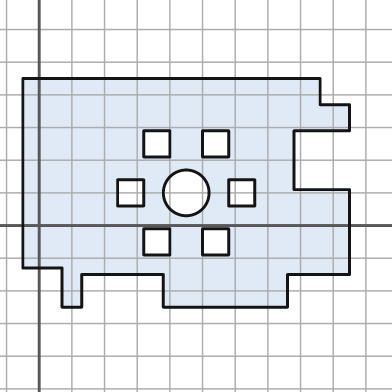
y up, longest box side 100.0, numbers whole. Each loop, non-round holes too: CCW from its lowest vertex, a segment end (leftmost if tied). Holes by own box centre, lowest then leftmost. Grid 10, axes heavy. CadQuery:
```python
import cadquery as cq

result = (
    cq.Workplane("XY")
    .moveTo(7.0, -25.0)
    .lineTo(13.0, -25.0)
    .lineTo(13.0, -15.0)
    .lineTo(38.0, -15.0)
    .lineTo(38.0, -25.0)
    .lineTo(76.0, -25.0)
    .lineTo(76.0, -15.0)
    .lineTo(95.0, -15.0)
    .lineTo(95.0, 11.0)
    .lineTo(78.0, 11.0)
    .lineTo(78.0, 29.0)
    .lineTo(95.0, 29.0)
    .lineTo(95.0, 37.0)
    .lineTo(86.0, 37.0)
    .lineTo(86.0, 45.0)
    .lineTo(-5.0, 45.0)
    .lineTo(-5.0, -13.0)
    .lineTo(7.0, -13.0)
    .close()
    .moveTo(32.0, -9.0)
    .lineTo(40.0, -9.0)
    .lineTo(40.0, -1.0)
    .lineTo(32.0, -1.0)
    .close()
    .moveTo(50.0, -9.0)
    .lineTo(58.0, -9.0)
    .lineTo(58.0, -1.0)
    .lineTo(50.0, -1.0)
    .close()
    .moveTo(24.0, 6.0)
    .lineTo(32.0, 6.0)
    .lineTo(32.0, 14.0)
    .lineTo(24.0, 14.0)
    .close()
    .moveTo(45.0, 10.0)
    .circle(7.0)
    .moveTo(58.0, 6.0)
    .lineTo(66.0, 6.0)
    .lineTo(66.0, 14.0)
    .lineTo(58.0, 14.0)
    .close()
    .moveTo(32.0, 21.0)
    .lineTo(40.0, 21.0)
    .lineTo(40.0, 29.0)
    .lineTo(32.0, 29.0)
    .close()
    .moveTo(50.0, 21.0)
    .lineTo(58.0, 21.0)
    .lineTo(58.0, 29.0)
    .lineTo(50.0, 29.0)
    .close()
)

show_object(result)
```